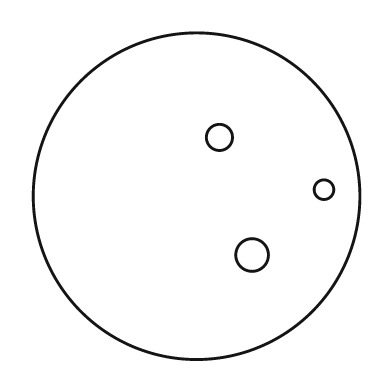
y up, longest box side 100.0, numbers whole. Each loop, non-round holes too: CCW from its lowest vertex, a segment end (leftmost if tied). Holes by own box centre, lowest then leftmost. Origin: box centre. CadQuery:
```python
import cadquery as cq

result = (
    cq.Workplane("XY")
    .moveTo(0.0, 0.0)
    .circle(50.0)
    .moveTo(17.0, -18.0)
    .circle(5.0)
    .moveTo(39.0, 2.0)
    .circle(3.0)
    .moveTo(7.0, 18.0)
    .circle(4.0)
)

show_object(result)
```